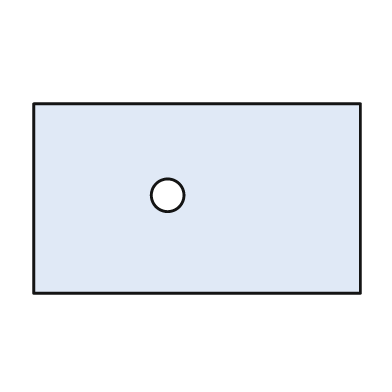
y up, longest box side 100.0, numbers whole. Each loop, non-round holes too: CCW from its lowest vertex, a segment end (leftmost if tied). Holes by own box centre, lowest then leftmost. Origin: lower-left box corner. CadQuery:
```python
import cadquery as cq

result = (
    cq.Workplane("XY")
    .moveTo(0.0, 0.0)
    .lineTo(100.0, 0.0)
    .lineTo(100.0, 58.0)
    .lineTo(0.0, 58.0)
    .close()
    .moveTo(41.0, 30.0)
    .circle(5.0)
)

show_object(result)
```